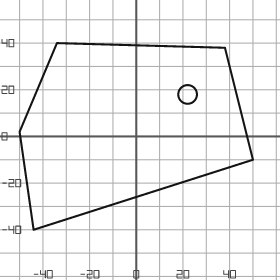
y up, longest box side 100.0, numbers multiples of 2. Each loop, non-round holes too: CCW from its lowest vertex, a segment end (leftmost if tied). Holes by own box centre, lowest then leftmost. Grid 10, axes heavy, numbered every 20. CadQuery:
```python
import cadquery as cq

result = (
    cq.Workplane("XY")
    .moveTo(-44.0, -40.0)
    .lineTo(50.0, -10.0)
    .lineTo(38.0, 38.0)
    .lineTo(-34.0, 40.0)
    .lineTo(-50.0, 2.0)
    .close()
    .moveTo(22.0, 18.0)
    .circle(4.0)
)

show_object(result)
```